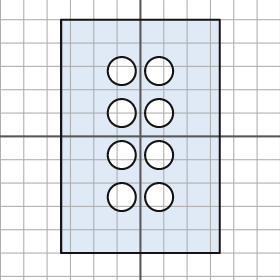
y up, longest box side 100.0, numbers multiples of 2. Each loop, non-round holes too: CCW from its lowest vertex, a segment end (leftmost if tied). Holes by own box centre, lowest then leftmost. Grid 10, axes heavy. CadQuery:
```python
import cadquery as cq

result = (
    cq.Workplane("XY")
    .moveTo(-34.0, -50.0)
    .lineTo(34.0, -50.0)
    .lineTo(34.0, 50.0)
    .lineTo(-34.0, 50.0)
    .close()
    .moveTo(-8.0, -26.0)
    .circle(6.0)
    .moveTo(8.0, -26.0)
    .circle(6.0)
    .moveTo(-8.0, -8.0)
    .circle(6.0)
    .moveTo(8.0, -8.0)
    .circle(6.0)
    .moveTo(-8.0, 10.0)
    .circle(6.0)
    .moveTo(8.0, 10.0)
    .circle(6.0)
    .moveTo(-8.0, 28.0)
    .circle(6.0)
    .moveTo(8.0, 28.0)
    .circle(6.0)
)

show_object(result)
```